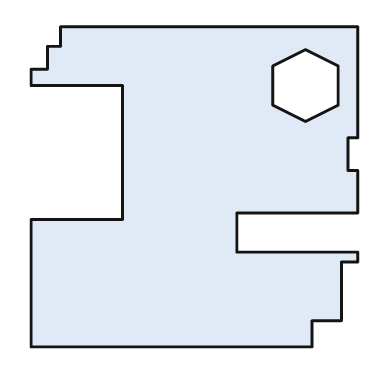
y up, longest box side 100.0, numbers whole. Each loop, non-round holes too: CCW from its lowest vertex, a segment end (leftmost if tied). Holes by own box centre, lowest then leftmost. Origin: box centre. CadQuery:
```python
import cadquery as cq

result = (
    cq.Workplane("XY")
    .moveTo(-50.0, -49.0)
    .lineTo(36.0, -49.0)
    .lineTo(36.0, -41.0)
    .lineTo(45.0, -41.0)
    .lineTo(45.0, -23.0)
    .lineTo(50.0, -23.0)
    .lineTo(50.0, -20.0)
    .lineTo(13.0, -20.0)
    .lineTo(13.0, -8.0)
    .lineTo(50.0, -8.0)
    .lineTo(50.0, 5.0)
    .lineTo(47.0, 5.0)
    .lineTo(47.0, 15.0)
    .lineTo(50.0, 15.0)
    .lineTo(50.0, 49.0)
    .lineTo(-41.0, 49.0)
    .lineTo(-41.0, 43.0)
    .lineTo(-45.0, 43.0)
    .lineTo(-45.0, 36.0)
    .lineTo(-50.0, 36.0)
    .lineTo(-50.0, 31.0)
    .lineTo(-22.0, 31.0)
    .lineTo(-22.0, -10.0)
    .lineTo(-50.0, -10.0)
    .close()
    .moveTo(34.0, 20.0)
    .lineTo(44.0, 25.0)
    .lineTo(44.0, 37.0)
    .lineTo(34.0, 42.0)
    .lineTo(24.0, 37.0)
    .lineTo(24.0, 25.0)
    .close()
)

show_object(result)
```